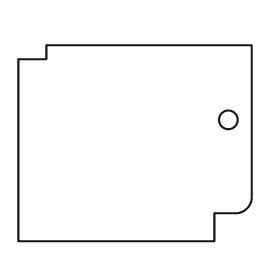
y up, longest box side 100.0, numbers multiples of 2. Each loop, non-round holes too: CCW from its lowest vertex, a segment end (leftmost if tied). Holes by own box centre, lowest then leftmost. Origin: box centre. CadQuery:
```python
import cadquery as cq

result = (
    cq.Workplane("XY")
    .moveTo(-50.0, -42.0)
    .lineTo(34.0, -42.0)
    .lineTo(34.0, -30.0)
    .lineTo(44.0, -30.0)
    .threePointArc((48.0, -28.0), (50.0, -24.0))
    .lineTo(50.0, 42.0)
    .lineTo(-38.0, 42.0)
    .lineTo(-38.0, 36.0)
    .lineTo(-50.0, 36.0)
    .close()
    .moveTo(40.0, 10.0)
    .circle(4.0)
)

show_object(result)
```